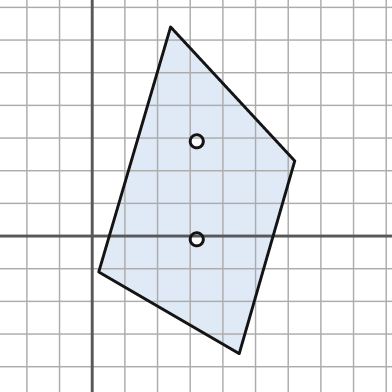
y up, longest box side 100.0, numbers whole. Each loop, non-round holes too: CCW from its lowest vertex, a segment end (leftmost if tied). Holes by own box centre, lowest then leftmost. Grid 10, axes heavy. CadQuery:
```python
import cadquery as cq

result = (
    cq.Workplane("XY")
    .moveTo(45.0, -36.0)
    .lineTo(62.0, 23.0)
    .lineTo(24.0, 64.0)
    .lineTo(2.0, -11.0)
    .close()
    .moveTo(32.0, -1.0)
    .circle(2.0)
    .moveTo(32.0, 29.0)
    .circle(2.0)
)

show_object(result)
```